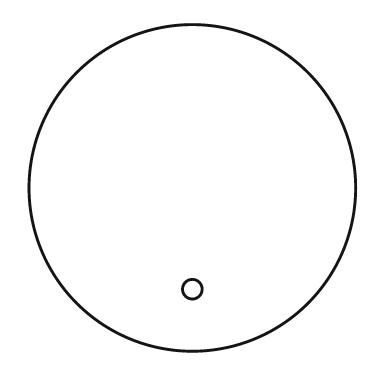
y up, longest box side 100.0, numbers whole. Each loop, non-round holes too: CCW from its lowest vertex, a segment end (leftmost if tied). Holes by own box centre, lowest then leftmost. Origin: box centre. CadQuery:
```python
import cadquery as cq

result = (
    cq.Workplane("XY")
    .moveTo(0.0, 0.0)
    .circle(50.0)
    .moveTo(0.0, -31.0)
    .circle(3.0)
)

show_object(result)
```